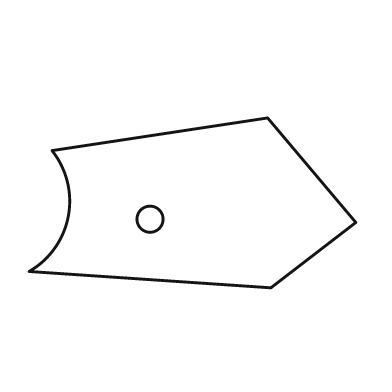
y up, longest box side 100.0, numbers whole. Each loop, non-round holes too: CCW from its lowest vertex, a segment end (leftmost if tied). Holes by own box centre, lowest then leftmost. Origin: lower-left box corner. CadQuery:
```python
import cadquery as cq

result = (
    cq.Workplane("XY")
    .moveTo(74.0, 0.0)
    .lineTo(100.0, 20.0)
    .lineTo(73.0, 52.0)
    .lineTo(7.0, 42.0)
    .threePointArc((12.0, 22.0), (0.0, 5.0))
    .close()
    .moveTo(37.0, 21.0)
    .circle(4.0)
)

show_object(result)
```